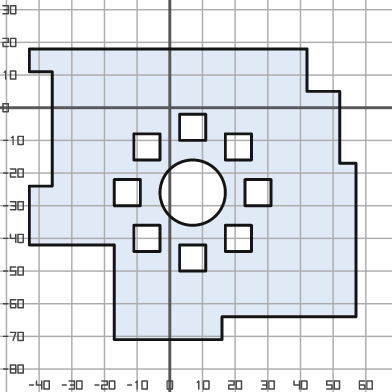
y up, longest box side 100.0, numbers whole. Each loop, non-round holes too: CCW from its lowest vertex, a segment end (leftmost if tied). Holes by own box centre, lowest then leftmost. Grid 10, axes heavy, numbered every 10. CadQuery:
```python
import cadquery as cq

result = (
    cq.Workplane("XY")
    .moveTo(-17.0, -71.0)
    .lineTo(16.0, -71.0)
    .lineTo(16.0, -64.0)
    .lineTo(57.0, -64.0)
    .lineTo(57.0, -17.0)
    .lineTo(52.0, -17.0)
    .lineTo(52.0, 5.0)
    .lineTo(42.0, 5.0)
    .lineTo(42.0, 18.0)
    .lineTo(-43.0, 18.0)
    .lineTo(-43.0, 11.0)
    .lineTo(-36.0, 11.0)
    .lineTo(-36.0, -24.0)
    .lineTo(-43.0, -24.0)
    .lineTo(-43.0, -42.0)
    .lineTo(-17.0, -42.0)
    .close()
    .moveTo(3.0, -50.0)
    .lineTo(11.0, -50.0)
    .lineTo(11.0, -42.0)
    .lineTo(3.0, -42.0)
    .close()
    .moveTo(-11.0, -44.0)
    .lineTo(-3.0, -44.0)
    .lineTo(-3.0, -36.0)
    .lineTo(-11.0, -36.0)
    .close()
    .moveTo(17.0, -44.0)
    .lineTo(25.0, -44.0)
    .lineTo(25.0, -36.0)
    .lineTo(17.0, -36.0)
    .close()
    .moveTo(-17.0, -30.0)
    .lineTo(-9.0, -30.0)
    .lineTo(-9.0, -22.0)
    .lineTo(-17.0, -22.0)
    .close()
    .moveTo(7.0, -26.0)
    .circle(10.0)
    .moveTo(23.0, -30.0)
    .lineTo(31.0, -30.0)
    .lineTo(31.0, -22.0)
    .lineTo(23.0, -22.0)
    .close()
    .moveTo(-11.0, -16.0)
    .lineTo(-3.0, -16.0)
    .lineTo(-3.0, -8.0)
    .lineTo(-11.0, -8.0)
    .close()
    .moveTo(17.0, -16.0)
    .lineTo(25.0, -16.0)
    .lineTo(25.0, -8.0)
    .lineTo(17.0, -8.0)
    .close()
    .moveTo(3.0, -10.0)
    .lineTo(11.0, -10.0)
    .lineTo(11.0, -2.0)
    .lineTo(3.0, -2.0)
    .close()
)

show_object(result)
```